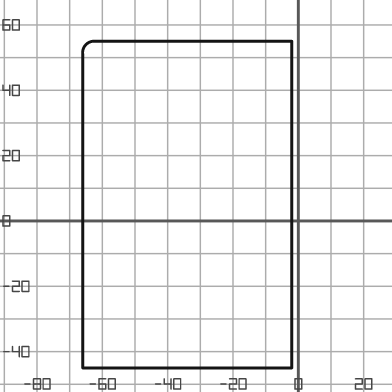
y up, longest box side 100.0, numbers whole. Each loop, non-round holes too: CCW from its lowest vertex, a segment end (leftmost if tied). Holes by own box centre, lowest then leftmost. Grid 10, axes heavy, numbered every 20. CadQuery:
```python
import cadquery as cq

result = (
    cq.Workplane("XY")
    .moveTo(-66.0, -45.0)
    .lineTo(-2.0, -45.0)
    .lineTo(-2.0, 55.0)
    .lineTo(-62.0, 55.0)
    .threePointArc((-65.0, 54.0), (-66.0, 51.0))
    .close()
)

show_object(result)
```